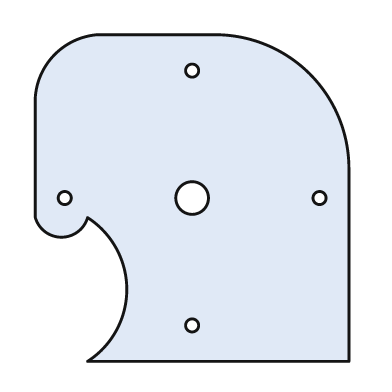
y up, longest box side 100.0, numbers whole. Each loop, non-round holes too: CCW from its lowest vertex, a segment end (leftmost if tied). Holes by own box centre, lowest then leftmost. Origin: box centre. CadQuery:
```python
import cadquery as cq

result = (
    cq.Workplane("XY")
    .moveTo(-32.0, -50.0)
    .lineTo(48.0, -50.0)
    .lineTo(48.0, 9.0)
    .threePointArc((36.0, 38.0), (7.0, 50.0))
    .lineTo(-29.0, 50.0)
    .threePointArc((-42.0, 44.0), (-48.0, 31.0))
    .lineTo(-48.0, -6.0)
    .threePointArc((-40.0, -12.0), (-32.0, -6.0))
    .threePointArc((-20.0, -28.0), (-32.0, -50.0))
    .close()
    .moveTo(0.0, -39.0)
    .circle(2.0)
    .moveTo(-39.0, 0.0)
    .circle(2.0)
    .moveTo(0.0, 0.0)
    .circle(5.0)
    .moveTo(39.0, 0.0)
    .circle(2.0)
    .moveTo(0.0, 39.0)
    .circle(2.0)
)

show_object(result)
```